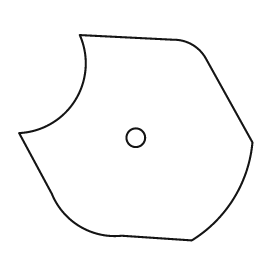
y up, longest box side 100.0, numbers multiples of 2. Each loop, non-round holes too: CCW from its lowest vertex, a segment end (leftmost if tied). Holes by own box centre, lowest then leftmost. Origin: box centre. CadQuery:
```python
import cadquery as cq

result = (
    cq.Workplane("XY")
    .moveTo(24.0, -44.0)
    .threePointArc((42.0, -26.0), (50.0, -2.0))
    .lineTo(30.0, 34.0)
    .threePointArc((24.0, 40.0), (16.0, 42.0))
    .lineTo(-24.0, 44.0)
    .threePointArc((-26.0, 16.0), (-50.0, 2.0))
    .lineTo(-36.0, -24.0)
    .threePointArc((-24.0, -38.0), (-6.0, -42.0))
    .close()
    .moveTo(0.0, 0.0)
    .circle(4.0)
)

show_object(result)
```